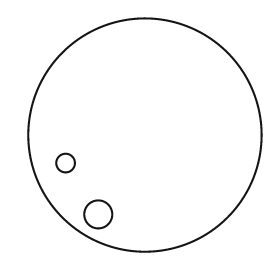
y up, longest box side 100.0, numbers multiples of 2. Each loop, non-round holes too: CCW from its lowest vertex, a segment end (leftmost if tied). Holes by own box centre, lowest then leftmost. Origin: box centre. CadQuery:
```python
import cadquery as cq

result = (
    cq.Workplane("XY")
    .moveTo(0.0, 0.0)
    .circle(50.0)
    .moveTo(-20.0, -34.0)
    .circle(6.0)
    .moveTo(-34.0, -12.0)
    .circle(4.0)
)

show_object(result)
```